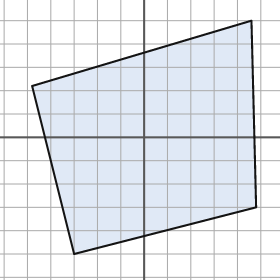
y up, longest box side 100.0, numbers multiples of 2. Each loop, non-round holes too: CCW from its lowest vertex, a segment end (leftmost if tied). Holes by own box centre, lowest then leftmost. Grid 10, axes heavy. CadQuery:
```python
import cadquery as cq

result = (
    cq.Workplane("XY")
    .moveTo(-30.0, -50.0)
    .lineTo(48.0, -30.0)
    .lineTo(46.0, 50.0)
    .lineTo(-48.0, 22.0)
    .close()
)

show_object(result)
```